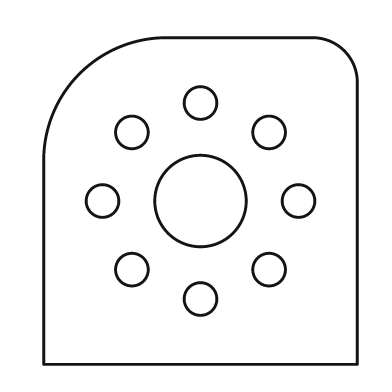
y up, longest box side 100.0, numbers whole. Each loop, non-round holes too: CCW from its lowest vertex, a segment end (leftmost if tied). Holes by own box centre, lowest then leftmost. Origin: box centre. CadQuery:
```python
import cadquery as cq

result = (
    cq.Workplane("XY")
    .moveTo(-48.0, -50.0)
    .lineTo(48.0, -50.0)
    .lineTo(48.0, 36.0)
    .threePointArc((44.0, 46.0), (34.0, 50.0))
    .lineTo(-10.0, 50.0)
    .threePointArc((-37.0, 39.0), (-48.0, 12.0))
    .close()
    .moveTo(0.0, -30.0)
    .circle(5.0)
    .moveTo(-21.0, -21.0)
    .circle(5.0)
    .moveTo(21.0, -21.0)
    .circle(5.0)
    .moveTo(-30.0, 0.0)
    .circle(5.0)
    .moveTo(0.0, 0.0)
    .circle(14.0)
    .moveTo(30.0, 0.0)
    .circle(5.0)
    .moveTo(-21.0, 21.0)
    .circle(5.0)
    .moveTo(21.0, 21.0)
    .circle(5.0)
    .moveTo(0.0, 30.0)
    .circle(5.0)
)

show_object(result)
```